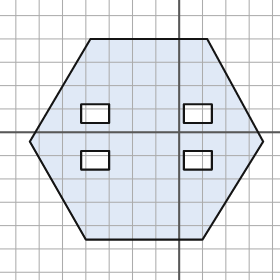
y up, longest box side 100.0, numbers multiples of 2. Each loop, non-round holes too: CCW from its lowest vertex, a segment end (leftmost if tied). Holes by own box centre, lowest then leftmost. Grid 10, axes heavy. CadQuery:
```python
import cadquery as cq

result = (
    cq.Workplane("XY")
    .moveTo(-40.0, -46.0)
    .lineTo(10.0, -46.0)
    .lineTo(36.0, -4.0)
    .lineTo(12.0, 40.0)
    .lineTo(-38.0, 40.0)
    .lineTo(-64.0, -4.0)
    .close()
    .moveTo(-42.0, -16.0)
    .lineTo(-30.0, -16.0)
    .lineTo(-30.0, -8.0)
    .lineTo(-42.0, -8.0)
    .close()
    .moveTo(2.0, -16.0)
    .lineTo(14.0, -16.0)
    .lineTo(14.0, -8.0)
    .lineTo(2.0, -8.0)
    .close()
    .moveTo(-42.0, 4.0)
    .lineTo(-30.0, 4.0)
    .lineTo(-30.0, 12.0)
    .lineTo(-42.0, 12.0)
    .close()
    .moveTo(2.0, 4.0)
    .lineTo(14.0, 4.0)
    .lineTo(14.0, 12.0)
    .lineTo(2.0, 12.0)
    .close()
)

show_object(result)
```